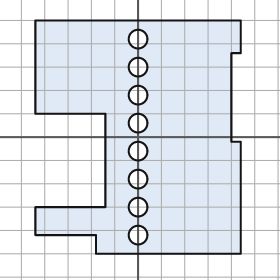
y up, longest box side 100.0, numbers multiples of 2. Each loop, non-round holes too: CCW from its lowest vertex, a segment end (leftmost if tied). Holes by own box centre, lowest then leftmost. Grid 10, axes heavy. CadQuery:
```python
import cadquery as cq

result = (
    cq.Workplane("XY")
    .moveTo(-18.0, -50.0)
    .lineTo(44.0, -50.0)
    .lineTo(44.0, -2.0)
    .lineTo(40.0, -2.0)
    .lineTo(40.0, 36.0)
    .lineTo(44.0, 36.0)
    .lineTo(44.0, 50.0)
    .lineTo(-44.0, 50.0)
    .lineTo(-44.0, 10.0)
    .lineTo(-14.0, 10.0)
    .lineTo(-14.0, -30.0)
    .lineTo(-44.0, -30.0)
    .lineTo(-44.0, -42.0)
    .lineTo(-18.0, -42.0)
    .close()
    .moveTo(0.0, -42.0)
    .circle(4.0)
    .moveTo(0.0, -30.0)
    .circle(4.0)
    .moveTo(0.0, -18.0)
    .circle(4.0)
    .moveTo(0.0, -6.0)
    .circle(4.0)
    .moveTo(0.0, 6.0)
    .circle(4.0)
    .moveTo(0.0, 18.0)
    .circle(4.0)
    .moveTo(0.0, 30.0)
    .circle(4.0)
    .moveTo(0.0, 42.0)
    .circle(4.0)
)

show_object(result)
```